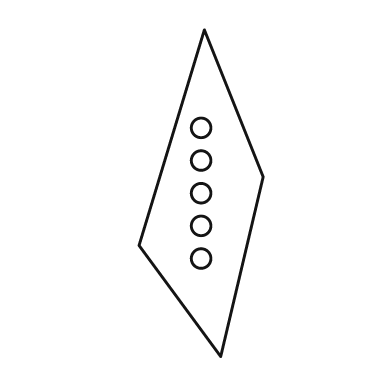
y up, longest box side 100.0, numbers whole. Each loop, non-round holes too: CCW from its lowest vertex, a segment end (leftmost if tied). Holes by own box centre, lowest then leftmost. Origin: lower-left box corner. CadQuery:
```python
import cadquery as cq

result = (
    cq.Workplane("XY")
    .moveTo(25.0, 0.0)
    .lineTo(38.0, 55.0)
    .lineTo(20.0, 100.0)
    .lineTo(0.0, 34.0)
    .close()
    .moveTo(19.0, 30.0)
    .circle(3.0)
    .moveTo(19.0, 40.0)
    .circle(3.0)
    .moveTo(19.0, 50.0)
    .circle(3.0)
    .moveTo(19.0, 60.0)
    .circle(3.0)
    .moveTo(19.0, 70.0)
    .circle(3.0)
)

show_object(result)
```